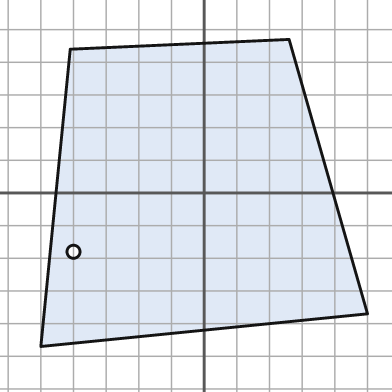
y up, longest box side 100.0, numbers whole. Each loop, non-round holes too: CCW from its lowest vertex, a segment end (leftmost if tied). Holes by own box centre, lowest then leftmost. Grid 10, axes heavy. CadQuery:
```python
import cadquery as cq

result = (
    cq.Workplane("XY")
    .moveTo(-50.0, -47.0)
    .lineTo(50.0, -37.0)
    .lineTo(26.0, 47.0)
    .lineTo(-41.0, 44.0)
    .close()
    .moveTo(-40.0, -18.0)
    .circle(2.0)
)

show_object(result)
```